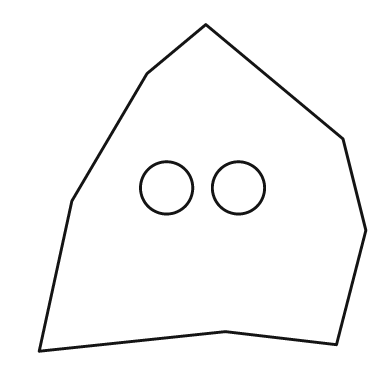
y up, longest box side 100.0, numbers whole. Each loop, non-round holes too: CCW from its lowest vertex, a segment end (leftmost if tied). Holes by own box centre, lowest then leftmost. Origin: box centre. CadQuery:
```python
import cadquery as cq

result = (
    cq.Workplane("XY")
    .moveTo(-50.0, -50.0)
    .lineTo(7.0, -44.0)
    .lineTo(41.0, -48.0)
    .lineTo(50.0, -13.0)
    .lineTo(43.0, 15.0)
    .lineTo(1.0, 50.0)
    .lineTo(-17.0, 35.0)
    .lineTo(-40.0, -4.0)
    .close()
    .moveTo(-11.0, 0.0)
    .circle(8.0)
    .moveTo(11.0, 0.0)
    .circle(8.0)
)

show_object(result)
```